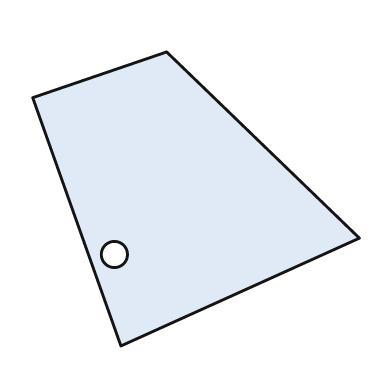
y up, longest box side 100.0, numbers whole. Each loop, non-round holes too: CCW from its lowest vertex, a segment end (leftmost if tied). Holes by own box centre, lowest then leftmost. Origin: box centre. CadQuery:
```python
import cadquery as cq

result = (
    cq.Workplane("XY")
    .moveTo(-23.0, -45.0)
    .lineTo(50.0, -12.0)
    .lineTo(-9.0, 45.0)
    .lineTo(-50.0, 31.0)
    .close()
    .moveTo(-25.0, -17.0)
    .circle(4.0)
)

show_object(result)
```